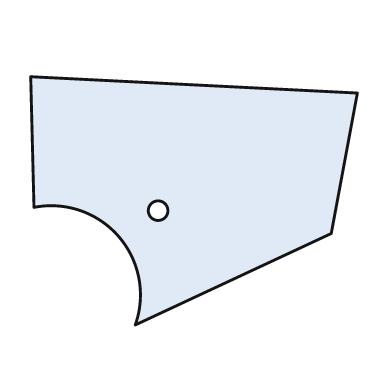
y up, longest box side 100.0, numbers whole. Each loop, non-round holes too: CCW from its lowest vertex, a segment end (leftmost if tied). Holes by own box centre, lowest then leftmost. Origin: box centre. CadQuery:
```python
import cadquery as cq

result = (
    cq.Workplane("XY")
    .moveTo(-18.0, -38.0)
    .lineTo(42.0, -10.0)
    .lineTo(50.0, 33.0)
    .lineTo(-50.0, 38.0)
    .lineTo(-49.0, -2.0)
    .threePointArc((-23.0, -11.0), (-18.0, -38.0))
    .close()
    .moveTo(-11.0, -3.0)
    .circle(3.0)
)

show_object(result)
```